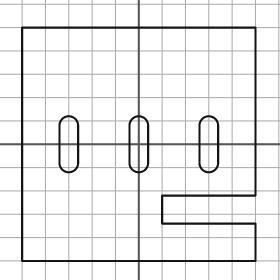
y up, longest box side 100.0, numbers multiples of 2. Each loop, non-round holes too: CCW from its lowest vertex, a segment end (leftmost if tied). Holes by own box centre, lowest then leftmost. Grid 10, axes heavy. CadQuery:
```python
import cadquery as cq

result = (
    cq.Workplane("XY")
    .moveTo(-50.0, -50.0)
    .lineTo(50.0, -50.0)
    .lineTo(50.0, -34.0)
    .lineTo(10.0, -34.0)
    .lineTo(10.0, -22.0)
    .lineTo(50.0, -22.0)
    .lineTo(50.0, 50.0)
    .lineTo(-50.0, 50.0)
    .close()
    .moveTo(-34.0, -8.0)
    .threePointArc((-30.0, -12.0), (-26.0, -8.0))
    .lineTo(-26.0, 8.0)
    .threePointArc((-30.0, 12.0), (-34.0, 8.0))
    .close()
    .moveTo(-4.0, -8.0)
    .threePointArc((0.0, -12.0), (4.0, -8.0))
    .lineTo(4.0, 8.0)
    .threePointArc((0.0, 12.0), (-4.0, 8.0))
    .close()
    .moveTo(26.0, -8.0)
    .threePointArc((30.0, -12.0), (34.0, -8.0))
    .lineTo(34.0, 8.0)
    .threePointArc((30.0, 12.0), (26.0, 8.0))
    .close()
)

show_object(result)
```